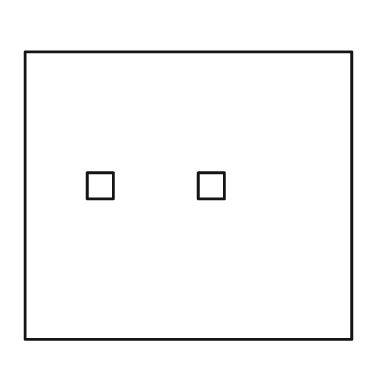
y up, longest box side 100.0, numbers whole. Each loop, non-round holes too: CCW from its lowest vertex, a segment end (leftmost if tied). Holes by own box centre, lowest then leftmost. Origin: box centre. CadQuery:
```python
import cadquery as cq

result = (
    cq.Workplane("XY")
    .moveTo(-50.0, -44.0)
    .lineTo(50.0, -44.0)
    .lineTo(50.0, 44.0)
    .lineTo(-50.0, 44.0)
    .close()
    .moveTo(-31.0, -1.0)
    .lineTo(-23.0, -1.0)
    .lineTo(-23.0, 7.0)
    .lineTo(-31.0, 7.0)
    .close()
    .moveTo(3.0, -1.0)
    .lineTo(11.0, -1.0)
    .lineTo(11.0, 7.0)
    .lineTo(3.0, 7.0)
    .close()
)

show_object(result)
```